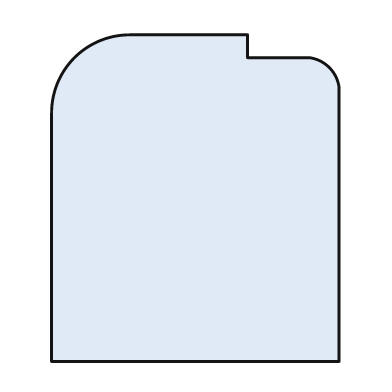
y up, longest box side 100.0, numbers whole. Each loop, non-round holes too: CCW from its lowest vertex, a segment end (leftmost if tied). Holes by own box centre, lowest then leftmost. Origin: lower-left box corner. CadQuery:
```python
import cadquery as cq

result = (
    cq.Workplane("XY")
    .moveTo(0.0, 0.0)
    .lineTo(88.0, 0.0)
    .lineTo(88.0, 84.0)
    .threePointArc((85.0, 90.0), (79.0, 93.0))
    .lineTo(60.0, 93.0)
    .lineTo(60.0, 100.0)
    .lineTo(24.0, 100.0)
    .threePointArc((7.0, 93.0), (0.0, 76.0))
    .close()
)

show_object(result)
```